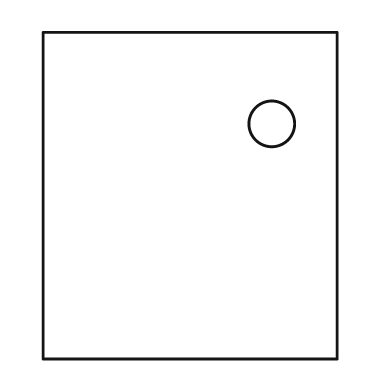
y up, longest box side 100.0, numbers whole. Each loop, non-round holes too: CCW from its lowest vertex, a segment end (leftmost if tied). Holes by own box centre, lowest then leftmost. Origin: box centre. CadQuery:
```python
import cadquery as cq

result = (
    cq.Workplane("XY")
    .moveTo(-45.0, -50.0)
    .lineTo(45.0, -50.0)
    .lineTo(45.0, 50.0)
    .lineTo(-45.0, 50.0)
    .close()
    .moveTo(25.0, 22.0)
    .circle(7.0)
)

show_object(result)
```